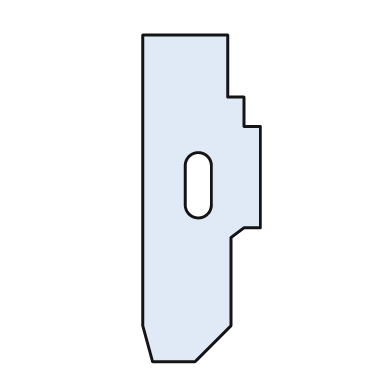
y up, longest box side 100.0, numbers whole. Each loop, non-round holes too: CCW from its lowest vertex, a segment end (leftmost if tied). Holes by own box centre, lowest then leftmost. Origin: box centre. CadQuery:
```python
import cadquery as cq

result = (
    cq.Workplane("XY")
    .moveTo(-15.0, -50.0)
    .lineTo(-2.0, -50.0)
    .lineTo(9.0, -39.0)
    .lineTo(9.0, -12.0)
    .lineTo(13.0, -9.0)
    .lineTo(18.0, -9.0)
    .lineTo(18.0, 22.0)
    .lineTo(13.0, 22.0)
    .lineTo(13.0, 31.0)
    .lineTo(8.0, 31.0)
    .lineTo(8.0, 50.0)
    .lineTo(-18.0, 50.0)
    .lineTo(-18.0, -39.0)
    .close()
    .moveTo(-5.0, -2.0)
    .threePointArc((-1.0, -6.0), (3.0, -2.0))
    .lineTo(3.0, 10.0)
    .threePointArc((-1.0, 14.0), (-5.0, 10.0))
    .close()
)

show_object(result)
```